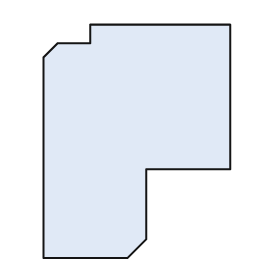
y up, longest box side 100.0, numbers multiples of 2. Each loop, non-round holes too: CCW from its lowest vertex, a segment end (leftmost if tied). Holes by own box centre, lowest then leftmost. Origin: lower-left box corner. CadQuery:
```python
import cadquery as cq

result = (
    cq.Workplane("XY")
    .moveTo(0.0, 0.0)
    .lineTo(36.0, 0.0)
    .lineTo(44.0, 8.0)
    .lineTo(44.0, 38.0)
    .lineTo(80.0, 38.0)
    .lineTo(80.0, 100.0)
    .lineTo(20.0, 100.0)
    .lineTo(20.0, 92.0)
    .lineTo(6.0, 92.0)
    .lineTo(0.0, 86.0)
    .close()
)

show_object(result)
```